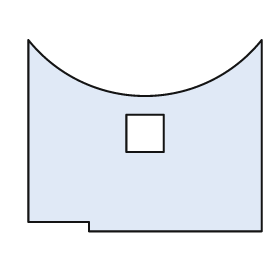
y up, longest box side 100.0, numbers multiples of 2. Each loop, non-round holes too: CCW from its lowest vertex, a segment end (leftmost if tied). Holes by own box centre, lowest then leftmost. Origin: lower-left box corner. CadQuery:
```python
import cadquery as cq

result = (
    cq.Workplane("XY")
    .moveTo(26.0, 0.0)
    .lineTo(100.0, 0.0)
    .lineTo(100.0, 82.0)
    .threePointArc((50.0, 58.0), (0.0, 82.0))
    .lineTo(0.0, 4.0)
    .lineTo(26.0, 4.0)
    .close()
    .moveTo(42.0, 34.0)
    .lineTo(58.0, 34.0)
    .lineTo(58.0, 50.0)
    .lineTo(42.0, 50.0)
    .close()
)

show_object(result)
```